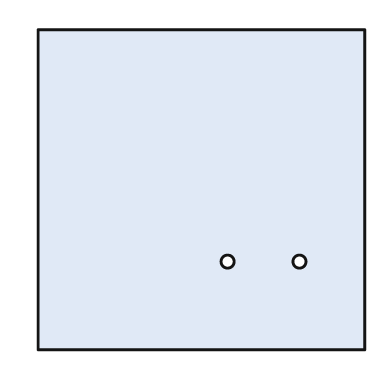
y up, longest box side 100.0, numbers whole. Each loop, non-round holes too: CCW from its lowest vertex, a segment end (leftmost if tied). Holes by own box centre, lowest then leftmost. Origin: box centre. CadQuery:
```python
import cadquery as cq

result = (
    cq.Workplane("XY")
    .moveTo(-50.0, -49.0)
    .lineTo(50.0, -49.0)
    .lineTo(50.0, 49.0)
    .lineTo(-50.0, 49.0)
    .close()
    .moveTo(8.0, -22.0)
    .circle(2.0)
    .moveTo(30.0, -22.0)
    .circle(2.0)
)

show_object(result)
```